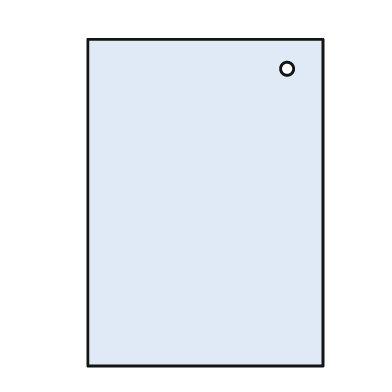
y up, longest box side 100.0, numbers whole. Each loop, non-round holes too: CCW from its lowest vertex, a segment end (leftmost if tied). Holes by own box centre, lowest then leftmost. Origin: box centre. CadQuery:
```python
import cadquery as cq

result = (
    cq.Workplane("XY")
    .moveTo(-36.0, -50.0)
    .lineTo(36.0, -50.0)
    .lineTo(36.0, 50.0)
    .lineTo(-36.0, 50.0)
    .close()
    .moveTo(25.0, 41.0)
    .circle(2.0)
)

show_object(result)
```